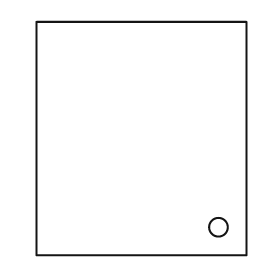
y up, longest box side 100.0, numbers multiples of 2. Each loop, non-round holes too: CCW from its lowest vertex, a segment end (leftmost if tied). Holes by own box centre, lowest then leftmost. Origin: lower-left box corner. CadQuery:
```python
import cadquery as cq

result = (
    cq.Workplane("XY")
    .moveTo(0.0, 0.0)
    .lineTo(90.0, 0.0)
    .lineTo(90.0, 100.0)
    .lineTo(0.0, 100.0)
    .close()
    .moveTo(78.0, 12.0)
    .circle(4.0)
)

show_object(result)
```